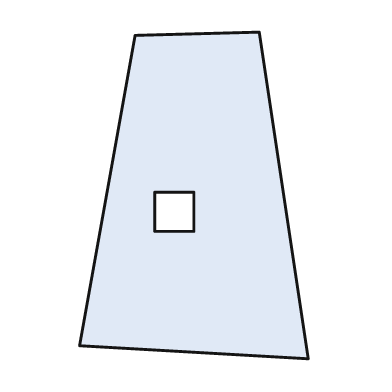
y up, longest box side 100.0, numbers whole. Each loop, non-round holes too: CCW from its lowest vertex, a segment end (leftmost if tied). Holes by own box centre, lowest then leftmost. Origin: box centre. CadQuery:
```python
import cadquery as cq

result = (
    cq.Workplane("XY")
    .moveTo(35.0, -50.0)
    .lineTo(20.0, 50.0)
    .lineTo(-18.0, 49.0)
    .lineTo(-35.0, -46.0)
    .close()
    .moveTo(-12.0, -11.0)
    .lineTo(0.0, -11.0)
    .lineTo(0.0, 1.0)
    .lineTo(-12.0, 1.0)
    .close()
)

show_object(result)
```